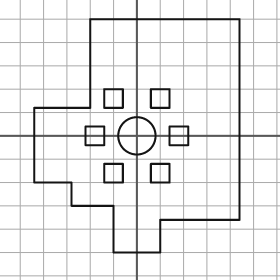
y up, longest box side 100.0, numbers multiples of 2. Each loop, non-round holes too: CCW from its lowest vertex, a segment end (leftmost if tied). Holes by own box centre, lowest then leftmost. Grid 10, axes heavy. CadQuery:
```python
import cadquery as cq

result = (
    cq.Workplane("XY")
    .moveTo(-10.0, -50.0)
    .lineTo(10.0, -50.0)
    .lineTo(10.0, -36.0)
    .lineTo(44.0, -36.0)
    .lineTo(44.0, 50.0)
    .lineTo(-20.0, 50.0)
    .lineTo(-20.0, 12.0)
    .lineTo(-44.0, 12.0)
    .lineTo(-44.0, -20.0)
    .lineTo(-28.0, -20.0)
    .lineTo(-28.0, -30.0)
    .lineTo(-10.0, -30.0)
    .close()
    .moveTo(-14.0, -20.0)
    .lineTo(-6.0, -20.0)
    .lineTo(-6.0, -12.0)
    .lineTo(-14.0, -12.0)
    .close()
    .moveTo(6.0, -20.0)
    .lineTo(14.0, -20.0)
    .lineTo(14.0, -12.0)
    .lineTo(6.0, -12.0)
    .close()
    .moveTo(-22.0, -4.0)
    .lineTo(-14.0, -4.0)
    .lineTo(-14.0, 4.0)
    .lineTo(-22.0, 4.0)
    .close()
    .moveTo(0.0, 0.0)
    .circle(8.0)
    .moveTo(14.0, -4.0)
    .lineTo(22.0, -4.0)
    .lineTo(22.0, 4.0)
    .lineTo(14.0, 4.0)
    .close()
    .moveTo(-14.0, 12.0)
    .lineTo(-6.0, 12.0)
    .lineTo(-6.0, 20.0)
    .lineTo(-14.0, 20.0)
    .close()
    .moveTo(6.0, 12.0)
    .lineTo(14.0, 12.0)
    .lineTo(14.0, 20.0)
    .lineTo(6.0, 20.0)
    .close()
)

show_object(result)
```